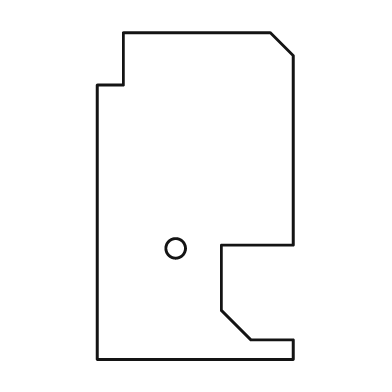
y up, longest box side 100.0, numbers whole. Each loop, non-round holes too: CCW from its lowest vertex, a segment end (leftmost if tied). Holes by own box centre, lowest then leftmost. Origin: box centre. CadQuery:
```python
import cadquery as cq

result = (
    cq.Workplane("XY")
    .moveTo(-30.0, -50.0)
    .lineTo(30.0, -50.0)
    .lineTo(30.0, -44.0)
    .lineTo(17.0, -44.0)
    .lineTo(8.0, -35.0)
    .lineTo(8.0, -15.0)
    .lineTo(30.0, -15.0)
    .lineTo(30.0, 43.0)
    .lineTo(23.0, 50.0)
    .lineTo(-22.0, 50.0)
    .lineTo(-22.0, 34.0)
    .lineTo(-30.0, 34.0)
    .close()
    .moveTo(-6.0, -16.0)
    .circle(3.0)
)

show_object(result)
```